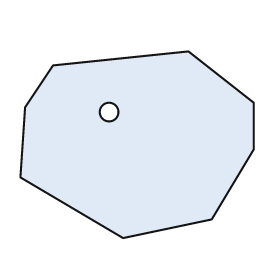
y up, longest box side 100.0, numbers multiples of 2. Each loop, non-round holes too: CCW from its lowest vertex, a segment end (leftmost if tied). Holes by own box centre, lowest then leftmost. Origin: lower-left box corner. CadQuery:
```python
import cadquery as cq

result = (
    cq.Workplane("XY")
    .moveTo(44.0, 0.0)
    .lineTo(82.0, 8.0)
    .lineTo(100.0, 38.0)
    .lineTo(100.0, 58.0)
    .lineTo(72.0, 80.0)
    .lineTo(14.0, 74.0)
    .lineTo(2.0, 56.0)
    .lineTo(0.0, 26.0)
    .close()
    .moveTo(38.0, 54.0)
    .circle(4.0)
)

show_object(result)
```